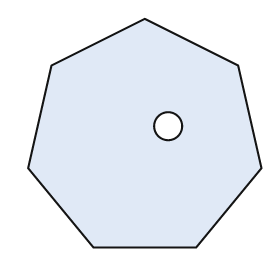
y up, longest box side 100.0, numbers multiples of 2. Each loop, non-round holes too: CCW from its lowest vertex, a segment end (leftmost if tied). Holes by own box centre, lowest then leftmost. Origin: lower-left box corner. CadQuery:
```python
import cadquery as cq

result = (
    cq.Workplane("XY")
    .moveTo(28.0, 0.0)
    .lineTo(72.0, 0.0)
    .lineTo(100.0, 34.0)
    .lineTo(90.0, 78.0)
    .lineTo(50.0, 98.0)
    .lineTo(10.0, 78.0)
    .lineTo(0.0, 34.0)
    .close()
    .moveTo(60.0, 52.0)
    .circle(6.0)
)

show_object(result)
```